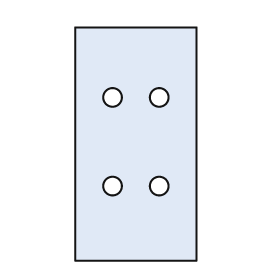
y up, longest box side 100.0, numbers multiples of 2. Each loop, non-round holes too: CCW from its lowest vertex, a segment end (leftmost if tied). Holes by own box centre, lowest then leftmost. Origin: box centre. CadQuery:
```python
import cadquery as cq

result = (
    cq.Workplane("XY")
    .moveTo(-26.0, -50.0)
    .lineTo(26.0, -50.0)
    .lineTo(26.0, 50.0)
    .lineTo(-26.0, 50.0)
    .close()
    .moveTo(-10.0, -18.0)
    .circle(4.0)
    .moveTo(10.0, -18.0)
    .circle(4.0)
    .moveTo(-10.0, 20.0)
    .circle(4.0)
    .moveTo(10.0, 20.0)
    .circle(4.0)
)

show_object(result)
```